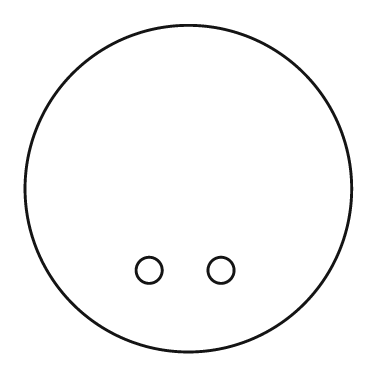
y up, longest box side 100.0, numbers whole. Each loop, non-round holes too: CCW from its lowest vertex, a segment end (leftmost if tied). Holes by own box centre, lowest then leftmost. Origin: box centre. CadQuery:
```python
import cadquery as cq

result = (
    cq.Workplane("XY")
    .moveTo(0.0, 0.0)
    .circle(50.0)
    .moveTo(-12.0, -25.0)
    .circle(4.0)
    .moveTo(10.0, -25.0)
    .circle(4.0)
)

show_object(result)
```